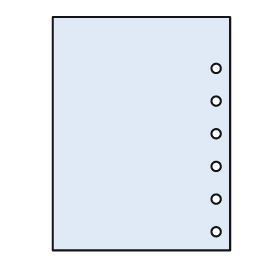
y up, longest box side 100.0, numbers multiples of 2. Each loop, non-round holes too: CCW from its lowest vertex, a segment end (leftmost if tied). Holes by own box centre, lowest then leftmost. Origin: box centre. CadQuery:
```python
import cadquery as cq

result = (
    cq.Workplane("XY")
    .moveTo(-38.0, -50.0)
    .lineTo(38.0, -50.0)
    .lineTo(38.0, 50.0)
    .lineTo(-38.0, 50.0)
    .close()
    .moveTo(32.0, -42.0)
    .circle(2.0)
    .moveTo(32.0, -28.0)
    .circle(2.0)
    .moveTo(32.0, -14.0)
    .circle(2.0)
    .moveTo(32.0, 0.0)
    .circle(2.0)
    .moveTo(32.0, 14.0)
    .circle(2.0)
    .moveTo(32.0, 28.0)
    .circle(2.0)
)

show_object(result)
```